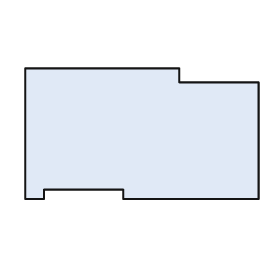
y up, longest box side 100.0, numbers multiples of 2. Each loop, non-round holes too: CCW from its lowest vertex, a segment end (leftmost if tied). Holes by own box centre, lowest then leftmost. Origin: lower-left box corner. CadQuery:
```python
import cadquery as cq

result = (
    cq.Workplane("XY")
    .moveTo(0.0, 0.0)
    .lineTo(8.0, 0.0)
    .lineTo(8.0, 4.0)
    .lineTo(42.0, 4.0)
    .lineTo(42.0, 0.0)
    .lineTo(100.0, 0.0)
    .lineTo(100.0, 50.0)
    .lineTo(66.0, 50.0)
    .lineTo(66.0, 56.0)
    .lineTo(0.0, 56.0)
    .close()
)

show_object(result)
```